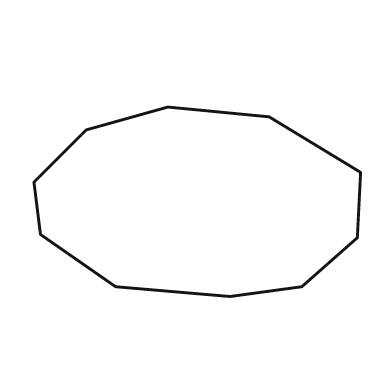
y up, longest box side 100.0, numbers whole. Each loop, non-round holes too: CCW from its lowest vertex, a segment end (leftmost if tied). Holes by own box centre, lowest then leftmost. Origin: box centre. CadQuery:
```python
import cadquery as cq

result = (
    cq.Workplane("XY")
    .moveTo(10.0, -29.0)
    .lineTo(32.0, -26.0)
    .lineTo(49.0, -11.0)
    .lineTo(50.0, 9.0)
    .lineTo(22.0, 26.0)
    .lineTo(-9.0, 29.0)
    .lineTo(-34.0, 22.0)
    .lineTo(-50.0, 6.0)
    .lineTo(-48.0, -10.0)
    .lineTo(-25.0, -26.0)
    .close()
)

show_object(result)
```